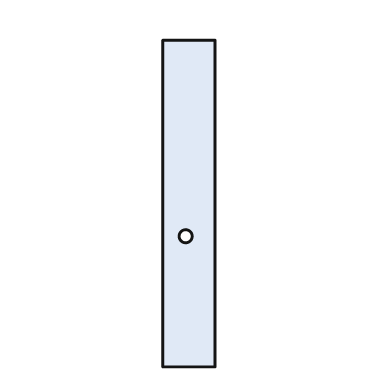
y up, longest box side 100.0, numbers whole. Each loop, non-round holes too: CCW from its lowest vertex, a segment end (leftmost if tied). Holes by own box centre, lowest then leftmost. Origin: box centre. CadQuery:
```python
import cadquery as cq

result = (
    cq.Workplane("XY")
    .moveTo(-8.0, -50.0)
    .lineTo(8.0, -50.0)
    .lineTo(8.0, 50.0)
    .lineTo(-8.0, 50.0)
    .close()
    .moveTo(-1.0, -10.0)
    .circle(2.0)
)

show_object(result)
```